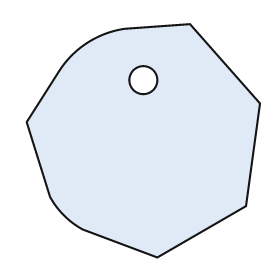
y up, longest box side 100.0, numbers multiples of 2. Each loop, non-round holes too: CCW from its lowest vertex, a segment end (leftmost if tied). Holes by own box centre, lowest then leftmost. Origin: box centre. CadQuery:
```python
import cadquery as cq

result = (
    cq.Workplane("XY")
    .moveTo(6.0, -50.0)
    .lineTo(44.0, -28.0)
    .lineTo(50.0, 16.0)
    .lineTo(20.0, 50.0)
    .lineTo(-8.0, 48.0)
    .threePointArc((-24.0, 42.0), (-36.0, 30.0))
    .lineTo(-50.0, 8.0)
    .lineTo(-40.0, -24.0)
    .threePointArc((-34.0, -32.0), (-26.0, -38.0))
    .close()
    .moveTo(0.0, 26.0)
    .circle(6.0)
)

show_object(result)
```